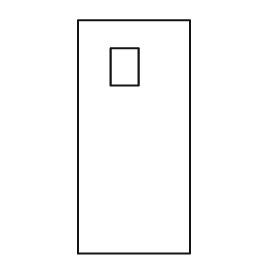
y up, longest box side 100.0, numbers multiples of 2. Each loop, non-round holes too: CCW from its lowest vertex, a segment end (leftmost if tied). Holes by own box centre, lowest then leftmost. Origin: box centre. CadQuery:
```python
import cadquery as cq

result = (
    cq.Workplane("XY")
    .moveTo(-24.0, -50.0)
    .lineTo(24.0, -50.0)
    .lineTo(24.0, 50.0)
    .lineTo(-24.0, 50.0)
    .close()
    .moveTo(-10.0, 22.0)
    .lineTo(2.0, 22.0)
    .lineTo(2.0, 38.0)
    .lineTo(-10.0, 38.0)
    .close()
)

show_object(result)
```